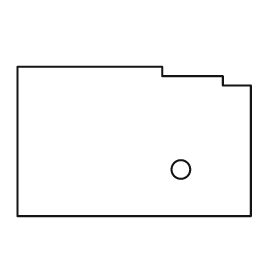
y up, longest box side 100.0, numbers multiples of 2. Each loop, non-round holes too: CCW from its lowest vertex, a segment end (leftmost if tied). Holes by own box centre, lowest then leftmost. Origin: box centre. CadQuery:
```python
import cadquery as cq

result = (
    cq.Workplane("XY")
    .moveTo(-50.0, -32.0)
    .lineTo(50.0, -32.0)
    .lineTo(50.0, 24.0)
    .lineTo(38.0, 24.0)
    .lineTo(38.0, 28.0)
    .lineTo(12.0, 28.0)
    .lineTo(12.0, 32.0)
    .lineTo(-50.0, 32.0)
    .close()
    .moveTo(20.0, -12.0)
    .circle(4.0)
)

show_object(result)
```